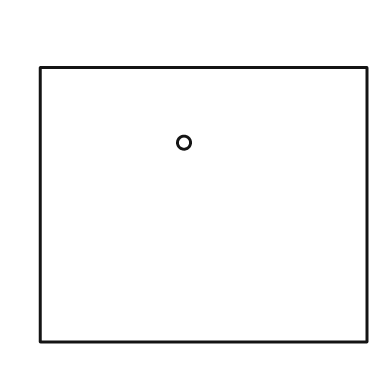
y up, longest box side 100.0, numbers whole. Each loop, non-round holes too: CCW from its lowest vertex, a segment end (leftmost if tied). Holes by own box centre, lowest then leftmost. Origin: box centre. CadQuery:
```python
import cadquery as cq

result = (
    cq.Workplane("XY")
    .moveTo(-50.0, -42.0)
    .lineTo(50.0, -42.0)
    .lineTo(50.0, 42.0)
    .lineTo(-50.0, 42.0)
    .close()
    .moveTo(-6.0, 19.0)
    .circle(2.0)
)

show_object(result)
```